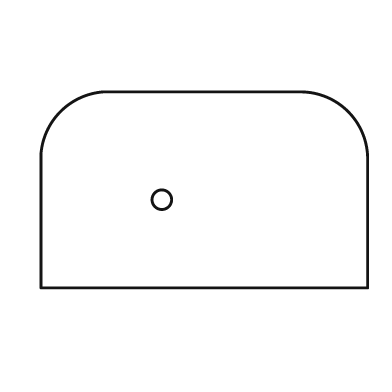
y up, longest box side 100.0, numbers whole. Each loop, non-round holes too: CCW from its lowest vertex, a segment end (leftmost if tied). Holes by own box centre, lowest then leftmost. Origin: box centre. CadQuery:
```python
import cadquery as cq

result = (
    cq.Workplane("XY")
    .moveTo(-50.0, -30.0)
    .lineTo(50.0, -30.0)
    .lineTo(50.0, 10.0)
    .threePointArc((44.0, 24.0), (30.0, 30.0))
    .lineTo(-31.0, 30.0)
    .threePointArc((-44.0, 24.0), (-50.0, 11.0))
    .close()
    .moveTo(-13.0, -3.0)
    .circle(3.0)
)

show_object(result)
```